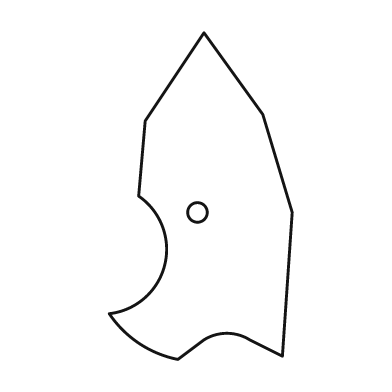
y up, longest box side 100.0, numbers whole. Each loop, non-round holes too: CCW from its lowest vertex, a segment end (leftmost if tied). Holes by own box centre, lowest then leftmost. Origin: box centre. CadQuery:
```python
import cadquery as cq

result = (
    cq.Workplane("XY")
    .moveTo(-7.0, -50.0)
    .lineTo(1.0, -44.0)
    .threePointArc((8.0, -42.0), (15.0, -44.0))
    .lineTo(25.0, -49.0)
    .lineTo(28.0, -5.0)
    .lineTo(19.0, 25.0)
    .lineTo(1.0, 50.0)
    .lineTo(-17.0, 23.0)
    .lineTo(-19.0, 0.0)
    .threePointArc((-11.0, -21.0), (-28.0, -36.0))
    .threePointArc((-19.0, -45.0), (-7.0, -50.0))
    .close()
    .moveTo(-1.0, -5.0)
    .circle(3.0)
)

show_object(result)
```